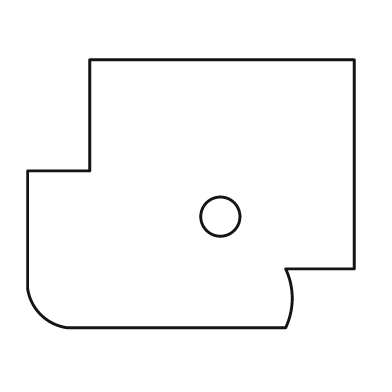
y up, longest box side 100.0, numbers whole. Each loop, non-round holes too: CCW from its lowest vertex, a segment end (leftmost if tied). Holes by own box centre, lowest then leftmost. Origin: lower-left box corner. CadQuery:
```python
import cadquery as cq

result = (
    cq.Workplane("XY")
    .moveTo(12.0, 0.0)
    .lineTo(79.0, 0.0)
    .threePointArc((81.0, 9.0), (79.0, 18.0))
    .lineTo(100.0, 18.0)
    .lineTo(100.0, 82.0)
    .lineTo(19.0, 82.0)
    .lineTo(19.0, 48.0)
    .lineTo(0.0, 48.0)
    .lineTo(0.0, 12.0)
    .threePointArc((4.0, 4.0), (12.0, 0.0))
    .close()
    .moveTo(59.0, 34.0)
    .circle(6.0)
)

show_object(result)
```